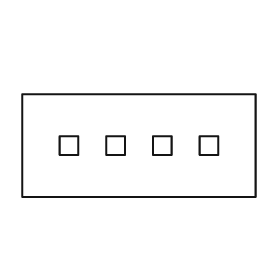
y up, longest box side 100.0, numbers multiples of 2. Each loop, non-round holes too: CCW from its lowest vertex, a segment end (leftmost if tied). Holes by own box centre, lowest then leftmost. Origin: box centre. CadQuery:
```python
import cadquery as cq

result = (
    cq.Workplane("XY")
    .moveTo(-50.0, -22.0)
    .lineTo(50.0, -22.0)
    .lineTo(50.0, 22.0)
    .lineTo(-50.0, 22.0)
    .close()
    .moveTo(-34.0, -4.0)
    .lineTo(-26.0, -4.0)
    .lineTo(-26.0, 4.0)
    .lineTo(-34.0, 4.0)
    .close()
    .moveTo(-14.0, -4.0)
    .lineTo(-6.0, -4.0)
    .lineTo(-6.0, 4.0)
    .lineTo(-14.0, 4.0)
    .close()
    .moveTo(6.0, -4.0)
    .lineTo(14.0, -4.0)
    .lineTo(14.0, 4.0)
    .lineTo(6.0, 4.0)
    .close()
    .moveTo(26.0, -4.0)
    .lineTo(34.0, -4.0)
    .lineTo(34.0, 4.0)
    .lineTo(26.0, 4.0)
    .close()
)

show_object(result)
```